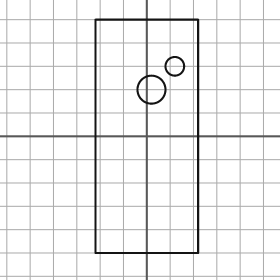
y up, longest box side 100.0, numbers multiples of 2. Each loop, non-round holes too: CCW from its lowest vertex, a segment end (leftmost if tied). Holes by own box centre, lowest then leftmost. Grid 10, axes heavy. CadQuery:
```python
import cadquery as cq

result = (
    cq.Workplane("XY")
    .moveTo(-22.0, -50.0)
    .lineTo(22.0, -50.0)
    .lineTo(22.0, 50.0)
    .lineTo(-22.0, 50.0)
    .close()
    .moveTo(2.0, 20.0)
    .circle(6.0)
    .moveTo(12.0, 30.0)
    .circle(4.0)
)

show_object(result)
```